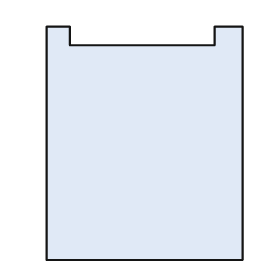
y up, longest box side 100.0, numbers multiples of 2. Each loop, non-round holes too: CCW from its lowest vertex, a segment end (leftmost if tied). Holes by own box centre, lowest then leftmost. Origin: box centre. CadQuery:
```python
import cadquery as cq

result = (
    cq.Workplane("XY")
    .moveTo(-42.0, -50.0)
    .lineTo(42.0, -50.0)
    .lineTo(42.0, 50.0)
    .lineTo(30.0, 50.0)
    .lineTo(30.0, 42.0)
    .lineTo(-32.0, 42.0)
    .lineTo(-32.0, 50.0)
    .lineTo(-42.0, 50.0)
    .close()
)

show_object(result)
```